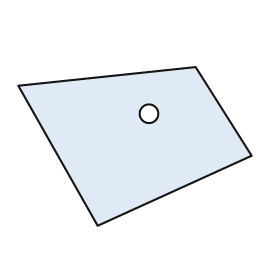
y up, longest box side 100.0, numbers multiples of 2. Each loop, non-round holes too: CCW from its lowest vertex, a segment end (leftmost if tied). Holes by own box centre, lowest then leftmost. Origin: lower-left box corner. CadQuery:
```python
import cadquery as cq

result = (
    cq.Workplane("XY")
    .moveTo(34.0, 0.0)
    .lineTo(100.0, 30.0)
    .lineTo(76.0, 68.0)
    .lineTo(0.0, 60.0)
    .close()
    .moveTo(56.0, 48.0)
    .circle(4.0)
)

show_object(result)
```